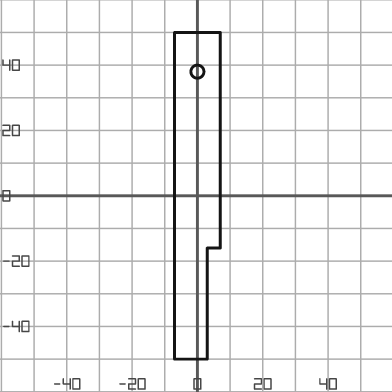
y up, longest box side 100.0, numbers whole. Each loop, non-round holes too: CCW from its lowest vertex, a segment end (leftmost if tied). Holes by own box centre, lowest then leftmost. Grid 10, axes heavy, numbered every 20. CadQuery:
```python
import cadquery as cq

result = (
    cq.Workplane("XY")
    .moveTo(-7.0, -50.0)
    .lineTo(3.0, -50.0)
    .lineTo(3.0, -16.0)
    .lineTo(7.0, -16.0)
    .lineTo(7.0, 50.0)
    .lineTo(-7.0, 50.0)
    .close()
    .moveTo(0.0, 38.0)
    .circle(2.0)
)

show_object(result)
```